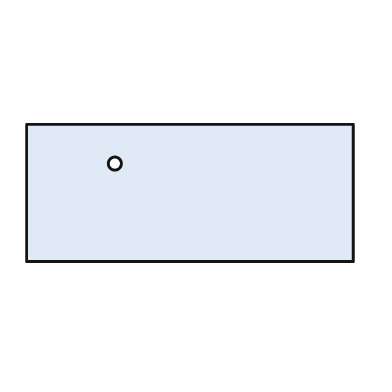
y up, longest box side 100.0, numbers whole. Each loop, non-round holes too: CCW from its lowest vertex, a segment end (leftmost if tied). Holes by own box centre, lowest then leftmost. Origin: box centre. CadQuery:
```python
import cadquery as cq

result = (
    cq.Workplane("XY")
    .moveTo(-50.0, -21.0)
    .lineTo(50.0, -21.0)
    .lineTo(50.0, 21.0)
    .lineTo(-50.0, 21.0)
    .close()
    .moveTo(-23.0, 9.0)
    .circle(2.0)
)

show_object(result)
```